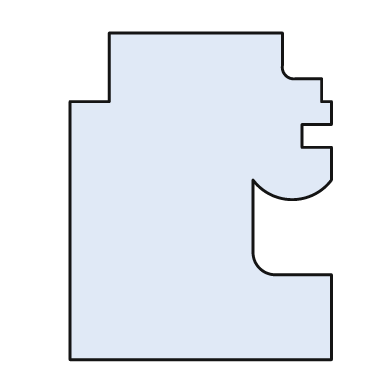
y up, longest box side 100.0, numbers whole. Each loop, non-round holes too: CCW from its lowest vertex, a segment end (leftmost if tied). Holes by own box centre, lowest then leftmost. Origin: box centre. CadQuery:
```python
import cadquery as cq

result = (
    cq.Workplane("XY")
    .moveTo(-40.0, -50.0)
    .lineTo(40.0, -50.0)
    .lineTo(40.0, -24.0)
    .lineTo(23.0, -24.0)
    .threePointArc((18.0, -22.0), (16.0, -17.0))
    .lineTo(16.0, 5.0)
    .threePointArc((28.0, -1.0), (40.0, 5.0))
    .lineTo(40.0, 15.0)
    .lineTo(31.0, 15.0)
    .lineTo(31.0, 22.0)
    .lineTo(40.0, 22.0)
    .lineTo(40.0, 29.0)
    .lineTo(37.0, 29.0)
    .lineTo(37.0, 36.0)
    .lineTo(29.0, 36.0)
    .threePointArc((26.0, 37.0), (25.0, 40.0))
    .lineTo(25.0, 50.0)
    .lineTo(-28.0, 50.0)
    .lineTo(-28.0, 29.0)
    .lineTo(-40.0, 29.0)
    .close()
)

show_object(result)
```